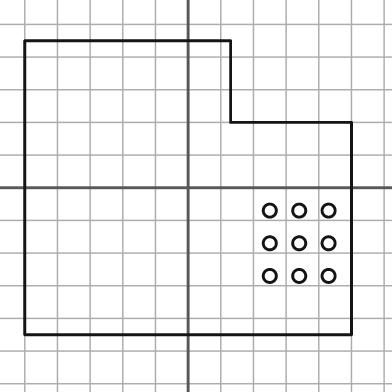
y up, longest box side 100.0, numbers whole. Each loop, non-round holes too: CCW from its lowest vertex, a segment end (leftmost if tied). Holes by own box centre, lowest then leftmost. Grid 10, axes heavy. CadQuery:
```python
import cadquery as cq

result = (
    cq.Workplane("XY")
    .moveTo(-50.0, -45.0)
    .lineTo(50.0, -45.0)
    .lineTo(50.0, 20.0)
    .lineTo(13.0, 20.0)
    .lineTo(13.0, 45.0)
    .lineTo(-50.0, 45.0)
    .close()
    .moveTo(25.0, -27.0)
    .circle(2.0)
    .moveTo(34.0, -27.0)
    .circle(2.0)
    .moveTo(43.0, -27.0)
    .circle(2.0)
    .moveTo(25.0, -17.0)
    .circle(2.0)
    .moveTo(34.0, -17.0)
    .circle(2.0)
    .moveTo(43.0, -17.0)
    .circle(2.0)
    .moveTo(25.0, -7.0)
    .circle(2.0)
    .moveTo(34.0, -7.0)
    .circle(2.0)
    .moveTo(43.0, -7.0)
    .circle(2.0)
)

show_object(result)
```